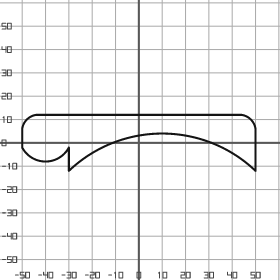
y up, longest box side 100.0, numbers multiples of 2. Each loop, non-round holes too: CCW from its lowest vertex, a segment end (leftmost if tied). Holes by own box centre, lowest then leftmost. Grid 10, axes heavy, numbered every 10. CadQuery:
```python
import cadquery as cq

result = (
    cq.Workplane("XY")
    .moveTo(-30.0, -12.0)
    .threePointArc((10.0, 4.0), (50.0, -12.0))
    .lineTo(50.0, 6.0)
    .threePointArc((48.0, 10.0), (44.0, 12.0))
    .lineTo(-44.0, 12.0)
    .threePointArc((-48.0, 10.0), (-50.0, 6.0))
    .lineTo(-50.0, -2.0)
    .threePointArc((-40.0, -8.0), (-30.0, -2.0))
    .close()
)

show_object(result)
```